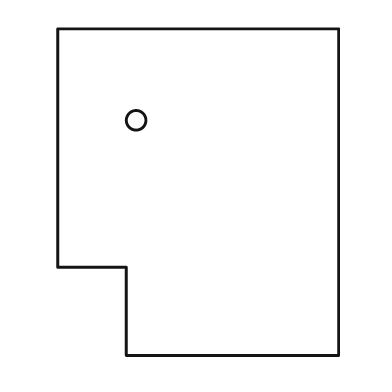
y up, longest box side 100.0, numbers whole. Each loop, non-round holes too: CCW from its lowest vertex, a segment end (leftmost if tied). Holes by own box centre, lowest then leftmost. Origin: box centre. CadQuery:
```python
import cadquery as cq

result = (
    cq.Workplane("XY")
    .moveTo(-22.0, -50.0)
    .lineTo(43.0, -50.0)
    .lineTo(43.0, 50.0)
    .lineTo(-43.0, 50.0)
    .lineTo(-43.0, -23.0)
    .lineTo(-22.0, -23.0)
    .close()
    .moveTo(-19.0, 22.0)
    .circle(3.0)
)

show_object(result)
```